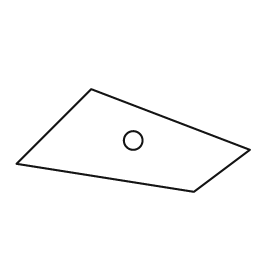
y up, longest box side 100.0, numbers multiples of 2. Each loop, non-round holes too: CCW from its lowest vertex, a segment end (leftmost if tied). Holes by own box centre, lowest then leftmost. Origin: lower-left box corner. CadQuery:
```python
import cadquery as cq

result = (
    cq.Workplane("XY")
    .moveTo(76.0, 0.0)
    .lineTo(100.0, 18.0)
    .lineTo(32.0, 44.0)
    .lineTo(0.0, 12.0)
    .close()
    .moveTo(50.0, 22.0)
    .circle(4.0)
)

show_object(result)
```